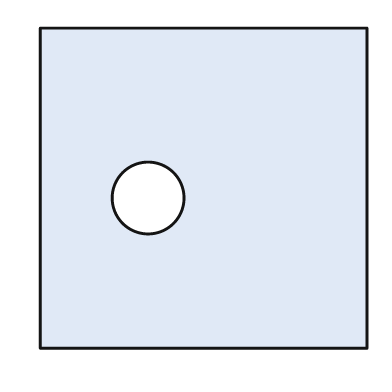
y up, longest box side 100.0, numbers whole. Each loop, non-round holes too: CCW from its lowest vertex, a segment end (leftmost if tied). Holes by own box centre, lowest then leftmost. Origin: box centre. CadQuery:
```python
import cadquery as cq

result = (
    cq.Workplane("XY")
    .moveTo(-50.0, -49.0)
    .lineTo(50.0, -49.0)
    .lineTo(50.0, 49.0)
    .lineTo(-50.0, 49.0)
    .close()
    .moveTo(-17.0, -3.0)
    .circle(11.0)
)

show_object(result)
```